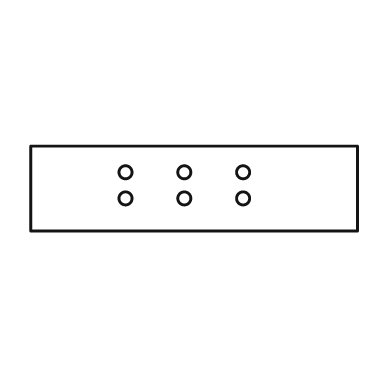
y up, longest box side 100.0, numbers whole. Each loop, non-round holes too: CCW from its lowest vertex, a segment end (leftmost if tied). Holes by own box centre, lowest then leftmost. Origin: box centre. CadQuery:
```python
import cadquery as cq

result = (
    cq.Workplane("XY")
    .moveTo(-50.0, -13.0)
    .lineTo(50.0, -13.0)
    .lineTo(50.0, 13.0)
    .lineTo(-50.0, 13.0)
    .close()
    .moveTo(-21.0, -3.0)
    .circle(2.0)
    .moveTo(-3.0, -3.0)
    .circle(2.0)
    .moveTo(15.0, -3.0)
    .circle(2.0)
    .moveTo(-21.0, 5.0)
    .circle(2.0)
    .moveTo(-3.0, 5.0)
    .circle(2.0)
    .moveTo(15.0, 5.0)
    .circle(2.0)
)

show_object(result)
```